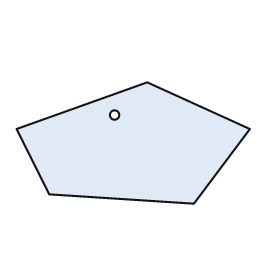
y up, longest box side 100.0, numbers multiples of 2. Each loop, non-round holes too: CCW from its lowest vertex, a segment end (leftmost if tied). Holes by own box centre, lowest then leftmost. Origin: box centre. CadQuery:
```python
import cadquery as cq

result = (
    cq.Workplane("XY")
    .moveTo(26.0, -26.0)
    .lineTo(50.0, 6.0)
    .lineTo(6.0, 26.0)
    .lineTo(-50.0, 6.0)
    .lineTo(-36.0, -22.0)
    .close()
    .moveTo(-8.0, 12.0)
    .circle(2.0)
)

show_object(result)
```